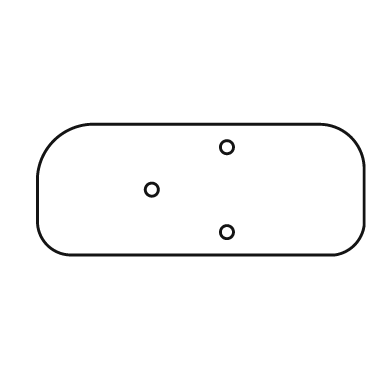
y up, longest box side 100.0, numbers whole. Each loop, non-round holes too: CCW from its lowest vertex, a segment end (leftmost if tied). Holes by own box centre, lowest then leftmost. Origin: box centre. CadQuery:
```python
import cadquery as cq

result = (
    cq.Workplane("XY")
    .moveTo(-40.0, -20.0)
    .lineTo(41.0, -20.0)
    .threePointArc((47.0, -17.0), (50.0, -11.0))
    .lineTo(50.0, 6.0)
    .threePointArc((46.0, 16.0), (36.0, 20.0))
    .lineTo(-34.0, 20.0)
    .threePointArc((-45.0, 15.0), (-50.0, 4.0))
    .lineTo(-50.0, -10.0)
    .threePointArc((-47.0, -17.0), (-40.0, -20.0))
    .close()
    .moveTo(8.0, -13.0)
    .circle(2.0)
    .moveTo(-15.0, 0.0)
    .circle(2.0)
    .moveTo(8.0, 13.0)
    .circle(2.0)
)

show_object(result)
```